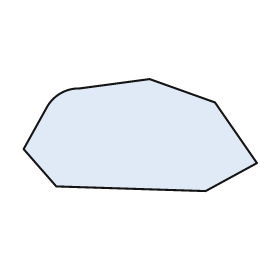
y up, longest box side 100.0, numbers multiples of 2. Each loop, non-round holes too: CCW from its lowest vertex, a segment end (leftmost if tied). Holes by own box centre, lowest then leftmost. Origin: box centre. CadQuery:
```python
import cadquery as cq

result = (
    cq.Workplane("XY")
    .moveTo(28.0, -24.0)
    .lineTo(50.0, -12.0)
    .lineTo(32.0, 14.0)
    .lineTo(4.0, 24.0)
    .lineTo(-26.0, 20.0)
    .threePointArc((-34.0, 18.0), (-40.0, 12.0))
    .lineTo(-50.0, -6.0)
    .lineTo(-36.0, -22.0)
    .close()
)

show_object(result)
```